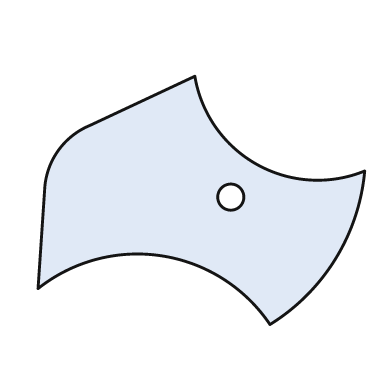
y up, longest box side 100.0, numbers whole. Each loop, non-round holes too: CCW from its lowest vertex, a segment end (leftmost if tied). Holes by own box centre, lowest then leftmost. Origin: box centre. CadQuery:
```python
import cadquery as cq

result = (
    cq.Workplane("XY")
    .moveTo(21.0, -38.0)
    .threePointArc((41.0, -18.0), (50.0, 9.0))
    .threePointArc((17.0, 11.0), (-2.0, 38.0))
    .lineTo(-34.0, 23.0)
    .threePointArc((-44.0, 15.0), (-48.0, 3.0))
    .lineTo(-50.0, -27.0)
    .threePointArc((-12.0, -17.0), (21.0, -38.0))
    .close()
    .moveTo(9.0, 1.0)
    .circle(4.0)
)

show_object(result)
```